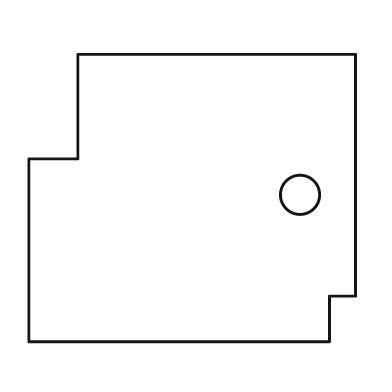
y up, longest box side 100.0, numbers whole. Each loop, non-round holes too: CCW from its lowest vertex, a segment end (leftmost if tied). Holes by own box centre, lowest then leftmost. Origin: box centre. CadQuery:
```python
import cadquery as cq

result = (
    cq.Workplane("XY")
    .moveTo(-50.0, -44.0)
    .lineTo(42.0, -44.0)
    .lineTo(42.0, -30.0)
    .lineTo(50.0, -30.0)
    .lineTo(50.0, 44.0)
    .lineTo(-35.0, 44.0)
    .lineTo(-35.0, 12.0)
    .lineTo(-50.0, 12.0)
    .close()
    .moveTo(33.0, 1.0)
    .circle(6.0)
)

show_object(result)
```